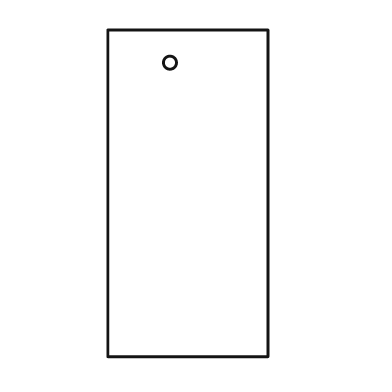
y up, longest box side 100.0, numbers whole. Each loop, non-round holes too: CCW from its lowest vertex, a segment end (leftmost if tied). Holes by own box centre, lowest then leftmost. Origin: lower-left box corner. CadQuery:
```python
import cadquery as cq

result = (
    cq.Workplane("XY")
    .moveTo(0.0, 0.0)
    .lineTo(49.0, 0.0)
    .lineTo(49.0, 100.0)
    .lineTo(0.0, 100.0)
    .close()
    .moveTo(19.0, 90.0)
    .circle(2.0)
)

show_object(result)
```